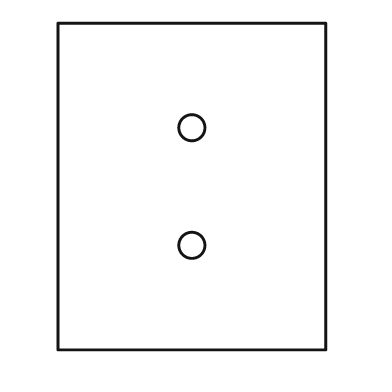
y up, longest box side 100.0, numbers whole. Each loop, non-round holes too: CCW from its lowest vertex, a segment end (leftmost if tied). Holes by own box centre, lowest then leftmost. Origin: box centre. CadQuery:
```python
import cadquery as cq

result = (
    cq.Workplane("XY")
    .moveTo(-41.0, -50.0)
    .lineTo(41.0, -50.0)
    .lineTo(41.0, 50.0)
    .lineTo(-41.0, 50.0)
    .close()
    .moveTo(0.0, -18.0)
    .circle(4.0)
    .moveTo(0.0, 18.0)
    .circle(4.0)
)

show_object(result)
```